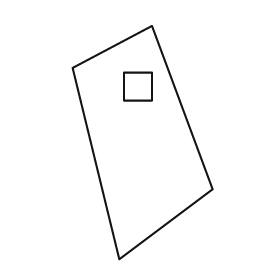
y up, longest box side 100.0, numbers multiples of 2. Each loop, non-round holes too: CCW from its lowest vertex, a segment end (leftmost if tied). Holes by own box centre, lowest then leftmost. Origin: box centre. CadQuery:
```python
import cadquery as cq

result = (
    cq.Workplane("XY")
    .moveTo(-10.0, -50.0)
    .lineTo(30.0, -20.0)
    .lineTo(4.0, 50.0)
    .lineTo(-30.0, 32.0)
    .close()
    .moveTo(-8.0, 18.0)
    .lineTo(4.0, 18.0)
    .lineTo(4.0, 30.0)
    .lineTo(-8.0, 30.0)
    .close()
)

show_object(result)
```